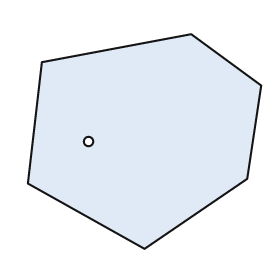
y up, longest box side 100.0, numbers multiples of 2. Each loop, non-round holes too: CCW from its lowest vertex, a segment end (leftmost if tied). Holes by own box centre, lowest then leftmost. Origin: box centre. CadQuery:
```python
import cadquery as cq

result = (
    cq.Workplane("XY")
    .moveTo(0.0, -46.0)
    .lineTo(44.0, -16.0)
    .lineTo(50.0, 24.0)
    .lineTo(20.0, 46.0)
    .lineTo(-44.0, 34.0)
    .lineTo(-50.0, -18.0)
    .close()
    .moveTo(-24.0, 0.0)
    .circle(2.0)
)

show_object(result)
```